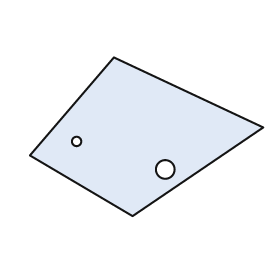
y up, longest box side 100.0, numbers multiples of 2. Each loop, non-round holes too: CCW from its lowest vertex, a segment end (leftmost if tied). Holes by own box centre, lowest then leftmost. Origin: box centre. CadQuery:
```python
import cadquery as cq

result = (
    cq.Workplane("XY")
    .moveTo(-6.0, -34.0)
    .lineTo(50.0, 4.0)
    .lineTo(-14.0, 34.0)
    .lineTo(-50.0, -8.0)
    .close()
    .moveTo(8.0, -14.0)
    .circle(4.0)
    .moveTo(-30.0, -2.0)
    .circle(2.0)
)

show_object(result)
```